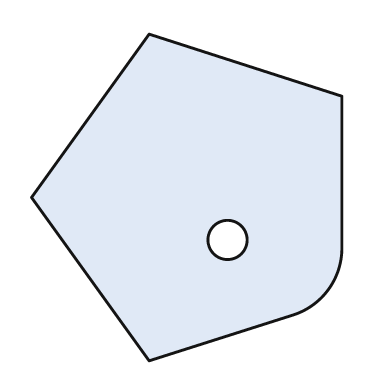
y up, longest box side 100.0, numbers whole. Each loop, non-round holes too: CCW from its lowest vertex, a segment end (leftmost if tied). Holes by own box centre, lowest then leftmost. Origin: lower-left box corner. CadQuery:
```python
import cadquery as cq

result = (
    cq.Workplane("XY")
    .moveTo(36.0, 0.0)
    .lineTo(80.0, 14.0)
    .threePointArc((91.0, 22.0), (95.0, 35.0))
    .lineTo(95.0, 81.0)
    .lineTo(36.0, 100.0)
    .lineTo(0.0, 50.0)
    .close()
    .moveTo(60.0, 37.0)
    .circle(6.0)
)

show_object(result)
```